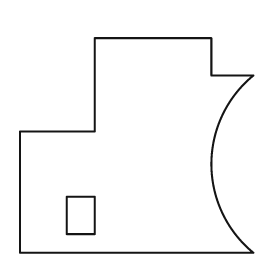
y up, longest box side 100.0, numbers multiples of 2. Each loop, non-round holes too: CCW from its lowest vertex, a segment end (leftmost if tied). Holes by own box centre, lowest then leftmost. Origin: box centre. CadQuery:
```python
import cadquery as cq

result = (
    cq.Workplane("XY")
    .moveTo(-50.0, -46.0)
    .lineTo(50.0, -46.0)
    .threePointArc((32.0, -8.0), (50.0, 30.0))
    .lineTo(32.0, 30.0)
    .lineTo(32.0, 46.0)
    .lineTo(-18.0, 46.0)
    .lineTo(-18.0, 6.0)
    .lineTo(-50.0, 6.0)
    .close()
    .moveTo(-30.0, -38.0)
    .lineTo(-18.0, -38.0)
    .lineTo(-18.0, -22.0)
    .lineTo(-30.0, -22.0)
    .close()
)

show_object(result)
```